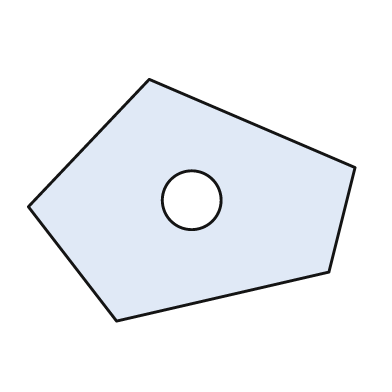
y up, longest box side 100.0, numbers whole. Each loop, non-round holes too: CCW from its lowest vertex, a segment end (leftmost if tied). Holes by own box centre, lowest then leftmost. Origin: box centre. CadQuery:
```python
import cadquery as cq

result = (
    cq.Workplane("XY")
    .moveTo(-23.0, -37.0)
    .lineTo(42.0, -22.0)
    .lineTo(50.0, 10.0)
    .lineTo(-13.0, 37.0)
    .lineTo(-50.0, -2.0)
    .close()
    .moveTo(0.0, 0.0)
    .circle(9.0)
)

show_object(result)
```